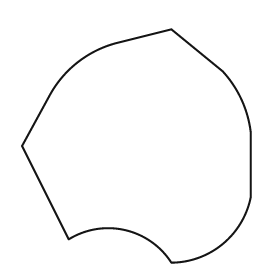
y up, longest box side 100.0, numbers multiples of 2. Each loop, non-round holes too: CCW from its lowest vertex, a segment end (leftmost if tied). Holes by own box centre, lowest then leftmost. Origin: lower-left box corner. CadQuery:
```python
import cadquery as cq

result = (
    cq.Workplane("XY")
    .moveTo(64.0, 0.0)
    .threePointArc((86.0, 8.0), (98.0, 28.0))
    .lineTo(98.0, 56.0)
    .threePointArc((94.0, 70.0), (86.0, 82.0))
    .lineTo(64.0, 100.0)
    .lineTo(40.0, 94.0)
    .threePointArc((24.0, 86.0), (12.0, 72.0))
    .lineTo(0.0, 50.0)
    .lineTo(20.0, 10.0)
    .threePointArc((44.0, 14.0), (64.0, 0.0))
    .close()
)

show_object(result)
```